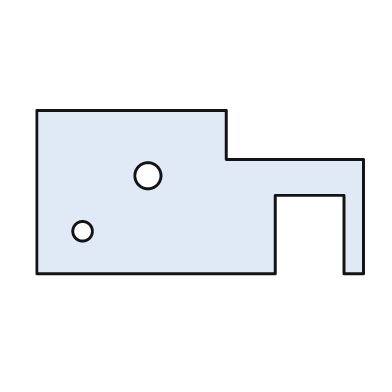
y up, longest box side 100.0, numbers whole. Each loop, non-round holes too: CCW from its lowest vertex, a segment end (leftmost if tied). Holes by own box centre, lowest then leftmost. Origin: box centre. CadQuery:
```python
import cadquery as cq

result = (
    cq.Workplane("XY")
    .moveTo(-50.0, -25.0)
    .lineTo(23.0, -25.0)
    .lineTo(23.0, -1.0)
    .lineTo(44.0, -1.0)
    .lineTo(44.0, -25.0)
    .lineTo(50.0, -25.0)
    .lineTo(50.0, 10.0)
    .lineTo(8.0, 10.0)
    .lineTo(8.0, 25.0)
    .lineTo(-50.0, 25.0)
    .close()
    .moveTo(-36.0, -12.0)
    .circle(3.0)
    .moveTo(-16.0, 5.0)
    .circle(4.0)
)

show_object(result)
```